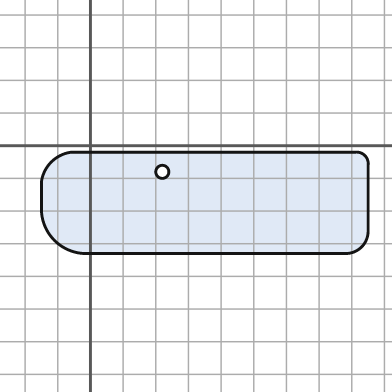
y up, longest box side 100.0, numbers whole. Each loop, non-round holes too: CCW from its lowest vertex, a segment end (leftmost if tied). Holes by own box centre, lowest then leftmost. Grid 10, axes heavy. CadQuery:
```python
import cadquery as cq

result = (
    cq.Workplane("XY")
    .moveTo(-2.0, -33.0)
    .lineTo(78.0, -33.0)
    .threePointArc((83.0, -31.0), (85.0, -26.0))
    .lineTo(85.0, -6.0)
    .threePointArc((84.0, -3.0), (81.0, -2.0))
    .lineTo(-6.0, -2.0)
    .threePointArc((-12.0, -5.0), (-15.0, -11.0))
    .lineTo(-15.0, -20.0)
    .threePointArc((-11.0, -29.0), (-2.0, -33.0))
    .close()
    .moveTo(22.0, -8.0)
    .circle(2.0)
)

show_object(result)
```